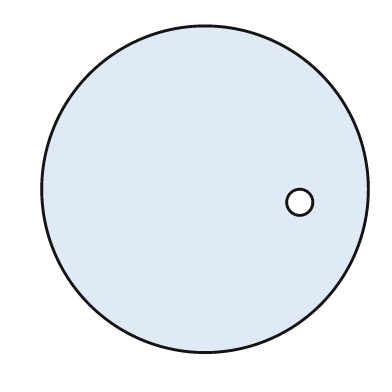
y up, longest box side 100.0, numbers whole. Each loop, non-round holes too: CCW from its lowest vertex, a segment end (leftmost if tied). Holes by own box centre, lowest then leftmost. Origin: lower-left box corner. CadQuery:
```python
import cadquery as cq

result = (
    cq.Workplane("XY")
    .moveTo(50.0, 50.0)
    .circle(50.0)
    .moveTo(79.0, 46.0)
    .circle(4.0)
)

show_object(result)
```